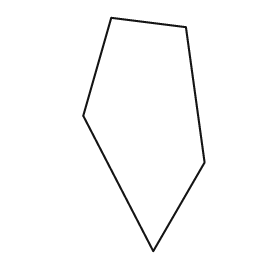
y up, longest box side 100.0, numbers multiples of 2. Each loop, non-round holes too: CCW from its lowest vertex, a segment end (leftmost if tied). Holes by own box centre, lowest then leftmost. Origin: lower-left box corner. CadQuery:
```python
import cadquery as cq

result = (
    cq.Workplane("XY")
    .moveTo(30.0, 0.0)
    .lineTo(52.0, 38.0)
    .lineTo(44.0, 96.0)
    .lineTo(12.0, 100.0)
    .lineTo(0.0, 58.0)
    .close()
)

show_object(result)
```